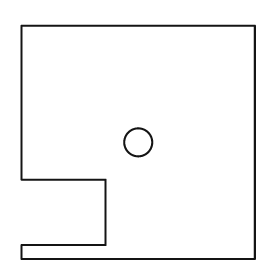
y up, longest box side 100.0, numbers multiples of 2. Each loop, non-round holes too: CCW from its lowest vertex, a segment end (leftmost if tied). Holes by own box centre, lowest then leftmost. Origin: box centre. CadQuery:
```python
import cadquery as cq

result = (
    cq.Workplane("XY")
    .moveTo(-50.0, -50.0)
    .lineTo(50.0, -50.0)
    .lineTo(50.0, 50.0)
    .lineTo(-50.0, 50.0)
    .lineTo(-50.0, -16.0)
    .lineTo(-14.0, -16.0)
    .lineTo(-14.0, -44.0)
    .lineTo(-50.0, -44.0)
    .close()
    .moveTo(0.0, 0.0)
    .circle(6.0)
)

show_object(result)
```